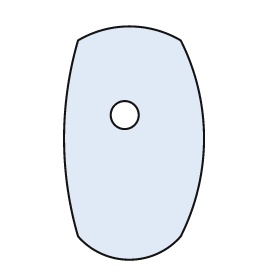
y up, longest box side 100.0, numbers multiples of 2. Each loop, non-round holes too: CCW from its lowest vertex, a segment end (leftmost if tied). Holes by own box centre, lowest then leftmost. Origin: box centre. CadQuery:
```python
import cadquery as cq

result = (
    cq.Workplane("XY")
    .moveTo(-24.0, -40.0)
    .threePointArc((-2.0, -50.0), (20.0, -40.0))
    .threePointArc((30.0, 2.0), (20.0, 44.0))
    .threePointArc((-2.0, 50.0), (-24.0, 44.0))
    .threePointArc((-30.0, 2.0), (-24.0, -40.0))
    .close()
    .moveTo(-4.0, 12.0)
    .circle(6.0)
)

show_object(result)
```